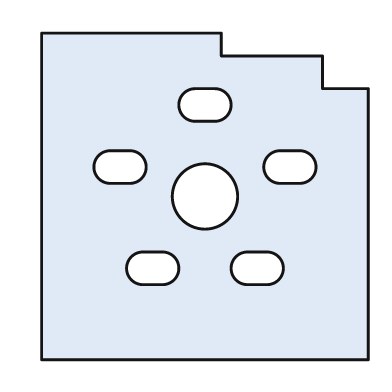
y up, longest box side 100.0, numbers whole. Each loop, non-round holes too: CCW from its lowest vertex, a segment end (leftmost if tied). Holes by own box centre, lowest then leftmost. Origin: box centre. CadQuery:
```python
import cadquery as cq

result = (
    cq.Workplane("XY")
    .moveTo(-50.0, -50.0)
    .lineTo(50.0, -50.0)
    .lineTo(50.0, 33.0)
    .lineTo(36.0, 33.0)
    .lineTo(36.0, 43.0)
    .lineTo(5.0, 43.0)
    .lineTo(5.0, 50.0)
    .lineTo(-50.0, 50.0)
    .close()
    .moveTo(-19.0, -27.0)
    .lineTo(-13.0, -27.0)
    .threePointArc((-8.0, -22.0), (-13.0, -17.0))
    .lineTo(-19.0, -17.0)
    .threePointArc((-24.0, -22.0), (-19.0, -27.0))
    .close()
    .moveTo(13.0, -27.0)
    .lineTo(19.0, -27.0)
    .threePointArc((24.0, -22.0), (19.0, -17.0))
    .lineTo(13.0, -17.0)
    .threePointArc((8.0, -22.0), (13.0, -27.0))
    .close()
    .moveTo(0.0, 0.0)
    .circle(10.0)
    .moveTo(-29.0, 4.0)
    .lineTo(-23.0, 4.0)
    .threePointArc((-18.0, 9.0), (-23.0, 14.0))
    .lineTo(-29.0, 14.0)
    .threePointArc((-34.0, 9.0), (-29.0, 4.0))
    .close()
    .moveTo(23.0, 4.0)
    .lineTo(29.0, 4.0)
    .threePointArc((34.0, 9.0), (29.0, 14.0))
    .lineTo(23.0, 14.0)
    .threePointArc((18.0, 9.0), (23.0, 4.0))
    .close()
    .moveTo(-3.0, 23.0)
    .lineTo(3.0, 23.0)
    .threePointArc((8.0, 28.0), (3.0, 33.0))
    .lineTo(-3.0, 33.0)
    .threePointArc((-8.0, 28.0), (-3.0, 23.0))
    .close()
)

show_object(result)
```